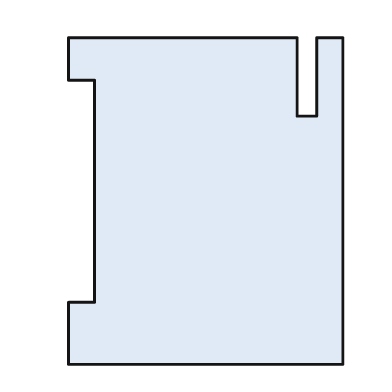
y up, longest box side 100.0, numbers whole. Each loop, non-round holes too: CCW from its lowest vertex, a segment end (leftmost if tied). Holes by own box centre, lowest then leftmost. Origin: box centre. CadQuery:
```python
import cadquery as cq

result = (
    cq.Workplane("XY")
    .moveTo(-42.0, -50.0)
    .lineTo(42.0, -50.0)
    .lineTo(42.0, 50.0)
    .lineTo(34.0, 50.0)
    .lineTo(34.0, 26.0)
    .lineTo(28.0, 26.0)
    .lineTo(28.0, 50.0)
    .lineTo(-42.0, 50.0)
    .lineTo(-42.0, 37.0)
    .lineTo(-34.0, 37.0)
    .lineTo(-34.0, -31.0)
    .lineTo(-42.0, -31.0)
    .close()
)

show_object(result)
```